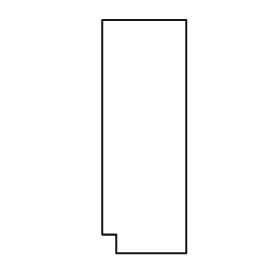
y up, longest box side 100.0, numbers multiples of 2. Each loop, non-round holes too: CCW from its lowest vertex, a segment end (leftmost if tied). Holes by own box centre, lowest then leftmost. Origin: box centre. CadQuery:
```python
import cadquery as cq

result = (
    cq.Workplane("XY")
    .moveTo(-12.0, -50.0)
    .lineTo(18.0, -50.0)
    .lineTo(18.0, 50.0)
    .lineTo(-18.0, 50.0)
    .lineTo(-18.0, -42.0)
    .lineTo(-12.0, -42.0)
    .close()
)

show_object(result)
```